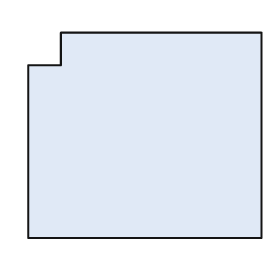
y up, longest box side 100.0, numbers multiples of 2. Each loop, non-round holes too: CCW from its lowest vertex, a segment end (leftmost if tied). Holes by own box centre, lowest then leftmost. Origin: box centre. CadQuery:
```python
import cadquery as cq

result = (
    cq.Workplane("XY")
    .moveTo(-50.0, -44.0)
    .lineTo(50.0, -44.0)
    .lineTo(50.0, 44.0)
    .lineTo(-36.0, 44.0)
    .lineTo(-36.0, 30.0)
    .lineTo(-50.0, 30.0)
    .close()
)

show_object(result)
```